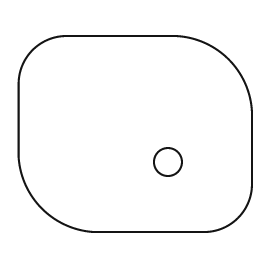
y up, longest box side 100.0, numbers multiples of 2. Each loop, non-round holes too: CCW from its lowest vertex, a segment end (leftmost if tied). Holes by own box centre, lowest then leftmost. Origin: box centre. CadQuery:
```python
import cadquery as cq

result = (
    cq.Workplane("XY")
    .moveTo(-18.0, -42.0)
    .lineTo(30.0, -42.0)
    .threePointArc((44.0, -36.0), (50.0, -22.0))
    .lineTo(50.0, 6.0)
    .threePointArc((40.0, 32.0), (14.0, 42.0))
    .lineTo(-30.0, 42.0)
    .threePointArc((-44.0, 36.0), (-50.0, 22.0))
    .lineTo(-50.0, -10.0)
    .threePointArc((-40.0, -32.0), (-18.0, -42.0))
    .close()
    .moveTo(14.0, -12.0)
    .circle(6.0)
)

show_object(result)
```